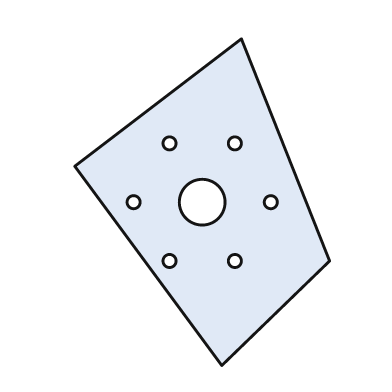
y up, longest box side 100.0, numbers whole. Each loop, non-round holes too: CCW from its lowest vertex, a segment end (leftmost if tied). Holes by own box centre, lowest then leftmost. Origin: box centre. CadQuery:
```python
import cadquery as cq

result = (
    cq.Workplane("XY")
    .moveTo(6.0, -50.0)
    .lineTo(39.0, -18.0)
    .lineTo(12.0, 50.0)
    .lineTo(-39.0, 11.0)
    .close()
    .moveTo(-10.0, -18.0)
    .circle(2.0)
    .moveTo(10.0, -18.0)
    .circle(2.0)
    .moveTo(-21.0, 0.0)
    .circle(2.0)
    .moveTo(0.0, 0.0)
    .circle(7.0)
    .moveTo(21.0, 0.0)
    .circle(2.0)
    .moveTo(-10.0, 18.0)
    .circle(2.0)
    .moveTo(10.0, 18.0)
    .circle(2.0)
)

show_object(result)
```